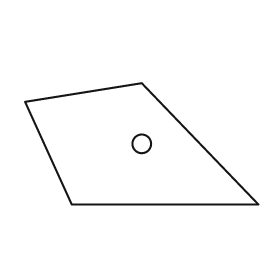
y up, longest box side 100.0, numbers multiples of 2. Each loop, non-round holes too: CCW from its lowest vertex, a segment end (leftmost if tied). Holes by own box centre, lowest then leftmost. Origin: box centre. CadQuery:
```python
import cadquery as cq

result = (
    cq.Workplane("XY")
    .moveTo(-30.0, -26.0)
    .lineTo(50.0, -26.0)
    .lineTo(0.0, 26.0)
    .lineTo(-50.0, 18.0)
    .close()
    .moveTo(0.0, 0.0)
    .circle(4.0)
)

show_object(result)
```